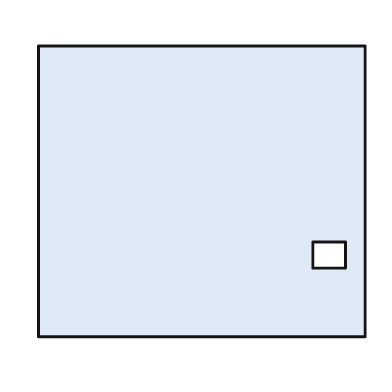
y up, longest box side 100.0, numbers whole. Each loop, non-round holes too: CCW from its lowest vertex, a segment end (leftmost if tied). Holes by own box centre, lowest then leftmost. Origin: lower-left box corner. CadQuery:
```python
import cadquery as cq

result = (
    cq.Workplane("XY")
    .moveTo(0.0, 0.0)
    .lineTo(100.0, 0.0)
    .lineTo(100.0, 89.0)
    .lineTo(0.0, 89.0)
    .close()
    .moveTo(84.0, 21.0)
    .lineTo(94.0, 21.0)
    .lineTo(94.0, 29.0)
    .lineTo(84.0, 29.0)
    .close()
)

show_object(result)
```